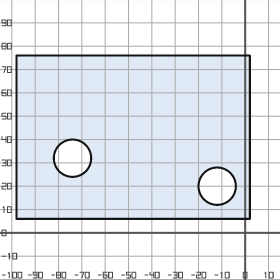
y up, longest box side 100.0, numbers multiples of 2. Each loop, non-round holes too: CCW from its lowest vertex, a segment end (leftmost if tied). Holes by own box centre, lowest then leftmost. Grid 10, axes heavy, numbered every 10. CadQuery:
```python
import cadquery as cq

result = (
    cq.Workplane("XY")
    .moveTo(-98.0, 6.0)
    .lineTo(2.0, 6.0)
    .lineTo(2.0, 76.0)
    .lineTo(-98.0, 76.0)
    .close()
    .moveTo(-12.0, 20.0)
    .circle(8.0)
    .moveTo(-74.0, 32.0)
    .circle(8.0)
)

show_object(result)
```